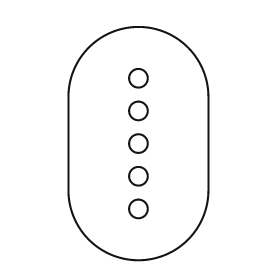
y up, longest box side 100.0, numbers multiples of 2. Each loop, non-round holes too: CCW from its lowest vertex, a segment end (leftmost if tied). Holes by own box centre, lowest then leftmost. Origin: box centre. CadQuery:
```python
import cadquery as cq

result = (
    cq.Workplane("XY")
    .moveTo(-30.0, -20.0)
    .threePointArc((0.0, -50.0), (30.0, -20.0))
    .lineTo(30.0, 20.0)
    .threePointArc((0.0, 50.0), (-30.0, 20.0))
    .close()
    .moveTo(0.0, -28.0)
    .circle(4.0)
    .moveTo(0.0, -14.0)
    .circle(4.0)
    .moveTo(0.0, 0.0)
    .circle(4.0)
    .moveTo(0.0, 14.0)
    .circle(4.0)
    .moveTo(0.0, 28.0)
    .circle(4.0)
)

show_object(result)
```